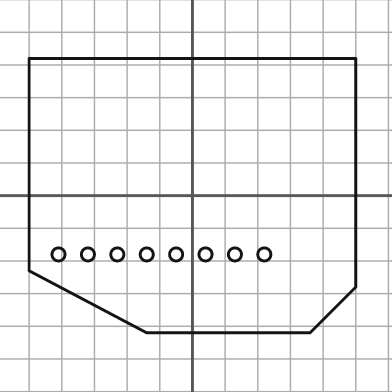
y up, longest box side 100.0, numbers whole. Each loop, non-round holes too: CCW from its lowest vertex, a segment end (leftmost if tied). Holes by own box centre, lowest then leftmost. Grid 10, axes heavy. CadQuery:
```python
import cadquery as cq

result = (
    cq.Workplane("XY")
    .moveTo(-14.0, -42.0)
    .lineTo(36.0, -42.0)
    .lineTo(50.0, -28.0)
    .lineTo(50.0, 42.0)
    .lineTo(-50.0, 42.0)
    .lineTo(-50.0, -23.0)
    .close()
    .moveTo(-41.0, -18.0)
    .circle(2.0)
    .moveTo(-32.0, -18.0)
    .circle(2.0)
    .moveTo(-23.0, -18.0)
    .circle(2.0)
    .moveTo(-14.0, -18.0)
    .circle(2.0)
    .moveTo(-5.0, -18.0)
    .circle(2.0)
    .moveTo(4.0, -18.0)
    .circle(2.0)
    .moveTo(13.0, -18.0)
    .circle(2.0)
    .moveTo(22.0, -18.0)
    .circle(2.0)
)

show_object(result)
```